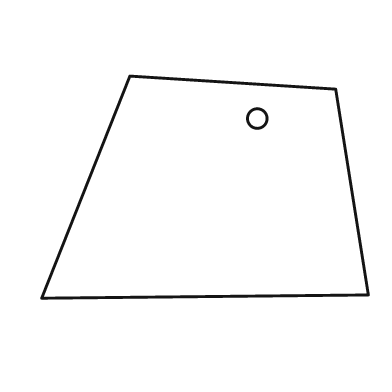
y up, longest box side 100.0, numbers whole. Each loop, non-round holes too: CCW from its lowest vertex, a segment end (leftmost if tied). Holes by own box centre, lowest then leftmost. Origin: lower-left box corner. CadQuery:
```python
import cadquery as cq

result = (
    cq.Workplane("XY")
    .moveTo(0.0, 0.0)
    .lineTo(100.0, 1.0)
    .lineTo(90.0, 64.0)
    .lineTo(27.0, 68.0)
    .close()
    .moveTo(66.0, 55.0)
    .circle(3.0)
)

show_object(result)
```